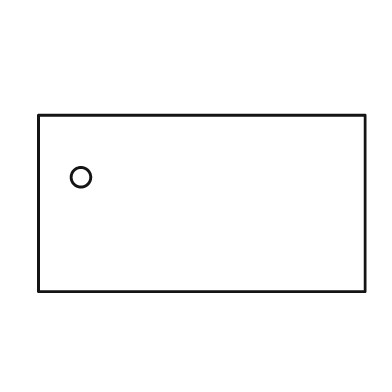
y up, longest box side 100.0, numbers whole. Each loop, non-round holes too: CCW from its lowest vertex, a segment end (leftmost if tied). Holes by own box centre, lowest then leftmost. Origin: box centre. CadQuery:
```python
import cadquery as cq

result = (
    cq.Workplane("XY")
    .moveTo(-50.0, -27.0)
    .lineTo(50.0, -27.0)
    .lineTo(50.0, 27.0)
    .lineTo(-50.0, 27.0)
    .close()
    .moveTo(-37.0, 8.0)
    .circle(3.0)
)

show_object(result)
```